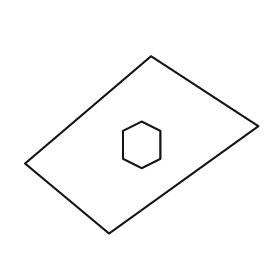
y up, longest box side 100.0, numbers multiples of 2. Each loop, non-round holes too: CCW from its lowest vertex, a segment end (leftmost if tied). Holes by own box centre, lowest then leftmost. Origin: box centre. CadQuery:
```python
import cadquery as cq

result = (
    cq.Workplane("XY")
    .moveTo(-14.0, -38.0)
    .lineTo(50.0, 8.0)
    .lineTo(4.0, 38.0)
    .lineTo(-50.0, -8.0)
    .close()
    .moveTo(0.0, -10.0)
    .lineTo(8.0, -6.0)
    .lineTo(8.0, 6.0)
    .lineTo(0.0, 10.0)
    .lineTo(-8.0, 6.0)
    .lineTo(-8.0, -6.0)
    .close()
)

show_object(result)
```